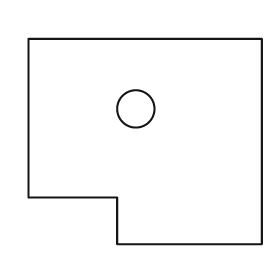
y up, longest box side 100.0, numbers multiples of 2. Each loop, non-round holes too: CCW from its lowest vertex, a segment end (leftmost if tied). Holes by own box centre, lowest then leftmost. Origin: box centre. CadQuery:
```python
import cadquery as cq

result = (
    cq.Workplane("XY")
    .moveTo(-12.0, -44.0)
    .lineTo(50.0, -44.0)
    .lineTo(50.0, 44.0)
    .lineTo(-50.0, 44.0)
    .lineTo(-50.0, -24.0)
    .lineTo(-12.0, -24.0)
    .close()
    .moveTo(-4.0, 14.0)
    .circle(8.0)
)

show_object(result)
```